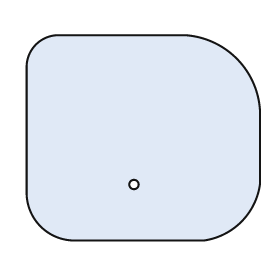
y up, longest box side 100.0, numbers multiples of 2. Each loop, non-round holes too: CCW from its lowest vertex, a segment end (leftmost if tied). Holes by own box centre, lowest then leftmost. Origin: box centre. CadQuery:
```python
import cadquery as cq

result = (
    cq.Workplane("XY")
    .moveTo(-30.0, -44.0)
    .lineTo(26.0, -44.0)
    .threePointArc((42.0, -36.0), (50.0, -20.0))
    .lineTo(50.0, 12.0)
    .threePointArc((40.0, 34.0), (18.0, 44.0))
    .lineTo(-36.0, 44.0)
    .threePointArc((-46.0, 40.0), (-50.0, 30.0))
    .lineTo(-50.0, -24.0)
    .threePointArc((-44.0, -38.0), (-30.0, -44.0))
    .close()
    .moveTo(-4.0, -20.0)
    .circle(2.0)
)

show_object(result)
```